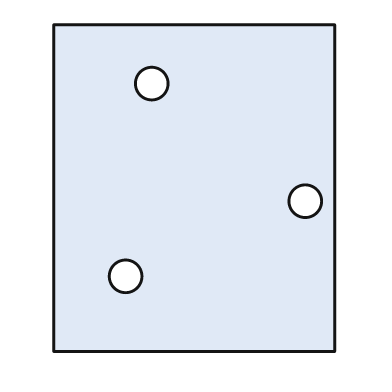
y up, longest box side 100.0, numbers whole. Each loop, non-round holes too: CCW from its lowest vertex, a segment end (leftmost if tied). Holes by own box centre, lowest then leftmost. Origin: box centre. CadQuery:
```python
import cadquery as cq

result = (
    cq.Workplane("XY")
    .moveTo(-43.0, -50.0)
    .lineTo(43.0, -50.0)
    .lineTo(43.0, 50.0)
    .lineTo(-43.0, 50.0)
    .close()
    .moveTo(-21.0, -27.0)
    .circle(5.0)
    .moveTo(34.0, -4.0)
    .circle(5.0)
    .moveTo(-13.0, 32.0)
    .circle(5.0)
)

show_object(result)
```